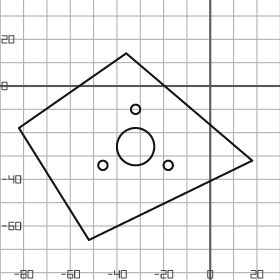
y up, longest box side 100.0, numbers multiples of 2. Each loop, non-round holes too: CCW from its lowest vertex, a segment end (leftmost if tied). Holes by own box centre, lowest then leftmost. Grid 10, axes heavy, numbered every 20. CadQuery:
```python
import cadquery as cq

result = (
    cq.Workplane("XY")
    .moveTo(-52.0, -66.0)
    .lineTo(18.0, -32.0)
    .lineTo(-36.0, 14.0)
    .lineTo(-82.0, -18.0)
    .close()
    .moveTo(-46.0, -34.0)
    .circle(2.0)
    .moveTo(-18.0, -34.0)
    .circle(2.0)
    .moveTo(-32.0, -26.0)
    .circle(8.0)
    .moveTo(-32.0, -10.0)
    .circle(2.0)
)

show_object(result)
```